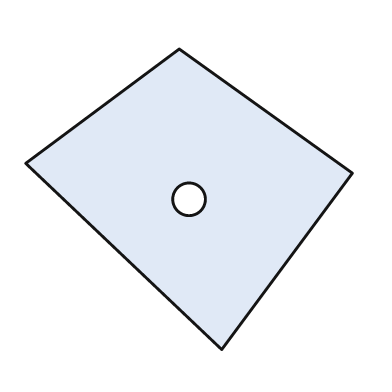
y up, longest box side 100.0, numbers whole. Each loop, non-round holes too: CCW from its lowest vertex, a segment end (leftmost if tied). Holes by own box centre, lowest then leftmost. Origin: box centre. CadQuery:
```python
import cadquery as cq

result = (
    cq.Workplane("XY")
    .moveTo(10.0, -46.0)
    .lineTo(50.0, 8.0)
    .lineTo(-3.0, 46.0)
    .lineTo(-50.0, 11.0)
    .close()
    .moveTo(0.0, 0.0)
    .circle(5.0)
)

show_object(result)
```